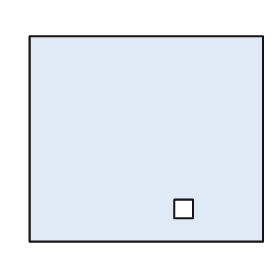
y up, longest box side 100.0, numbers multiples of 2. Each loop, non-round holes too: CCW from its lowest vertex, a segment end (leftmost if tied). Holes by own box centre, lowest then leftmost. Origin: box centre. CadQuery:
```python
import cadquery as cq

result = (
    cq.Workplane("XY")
    .moveTo(-50.0, -44.0)
    .lineTo(50.0, -44.0)
    .lineTo(50.0, 44.0)
    .lineTo(-50.0, 44.0)
    .close()
    .moveTo(12.0, -34.0)
    .lineTo(20.0, -34.0)
    .lineTo(20.0, -26.0)
    .lineTo(12.0, -26.0)
    .close()
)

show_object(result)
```